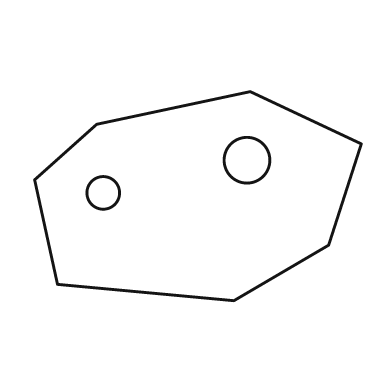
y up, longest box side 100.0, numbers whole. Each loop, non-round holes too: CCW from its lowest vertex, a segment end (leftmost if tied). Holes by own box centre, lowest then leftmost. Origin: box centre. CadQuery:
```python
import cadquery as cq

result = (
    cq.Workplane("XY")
    .moveTo(11.0, -32.0)
    .lineTo(40.0, -15.0)
    .lineTo(50.0, 16.0)
    .lineTo(16.0, 32.0)
    .lineTo(-31.0, 22.0)
    .lineTo(-50.0, 5.0)
    .lineTo(-43.0, -27.0)
    .close()
    .moveTo(-29.0, 1.0)
    .circle(5.0)
    .moveTo(15.0, 11.0)
    .circle(7.0)
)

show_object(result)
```